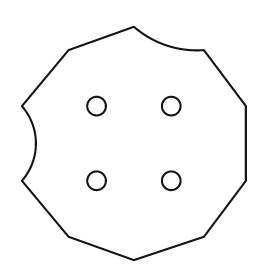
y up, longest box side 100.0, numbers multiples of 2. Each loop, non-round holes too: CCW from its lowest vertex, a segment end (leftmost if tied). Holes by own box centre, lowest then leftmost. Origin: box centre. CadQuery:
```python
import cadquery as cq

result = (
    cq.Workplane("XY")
    .moveTo(0.0, -50.0)
    .lineTo(30.0, -40.0)
    .lineTo(48.0, -16.0)
    .lineTo(48.0, 16.0)
    .lineTo(30.0, 40.0)
    .threePointArc((14.0, 42.0), (0.0, 50.0))
    .lineTo(-28.0, 40.0)
    .lineTo(-48.0, 16.0)
    .threePointArc((-42.0, 0.0), (-48.0, -16.0))
    .lineTo(-28.0, -40.0)
    .close()
    .moveTo(-16.0, -16.0)
    .circle(4.0)
    .moveTo(16.0, -16.0)
    .circle(4.0)
    .moveTo(-16.0, 16.0)
    .circle(4.0)
    .moveTo(16.0, 16.0)
    .circle(4.0)
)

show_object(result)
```